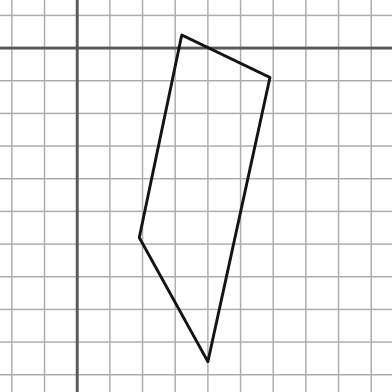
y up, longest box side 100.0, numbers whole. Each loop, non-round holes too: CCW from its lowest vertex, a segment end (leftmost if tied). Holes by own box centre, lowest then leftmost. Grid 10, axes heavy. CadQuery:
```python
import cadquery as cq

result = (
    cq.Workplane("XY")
    .moveTo(40.0, -96.0)
    .lineTo(59.0, -9.0)
    .lineTo(32.0, 4.0)
    .lineTo(19.0, -58.0)
    .close()
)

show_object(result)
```